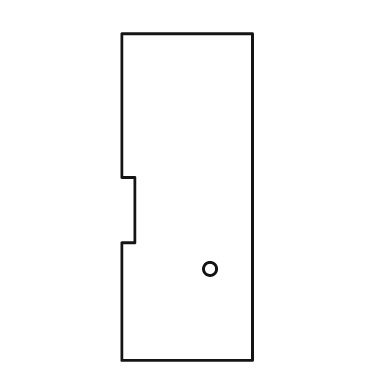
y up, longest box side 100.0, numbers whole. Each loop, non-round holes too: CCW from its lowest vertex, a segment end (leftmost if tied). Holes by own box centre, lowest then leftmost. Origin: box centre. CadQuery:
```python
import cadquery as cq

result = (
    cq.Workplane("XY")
    .moveTo(-20.0, -50.0)
    .lineTo(20.0, -50.0)
    .lineTo(20.0, 50.0)
    .lineTo(-20.0, 50.0)
    .lineTo(-20.0, 6.0)
    .lineTo(-16.0, 6.0)
    .lineTo(-16.0, -14.0)
    .lineTo(-20.0, -14.0)
    .close()
    .moveTo(7.0, -22.0)
    .circle(2.0)
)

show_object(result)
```